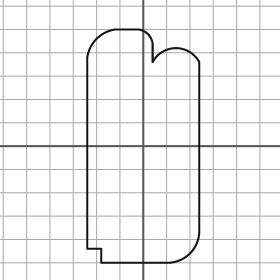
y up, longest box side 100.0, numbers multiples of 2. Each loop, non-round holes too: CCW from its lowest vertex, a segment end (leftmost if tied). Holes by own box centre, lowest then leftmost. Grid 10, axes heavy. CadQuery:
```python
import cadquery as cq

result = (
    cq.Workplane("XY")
    .moveTo(-18.0, -50.0)
    .lineTo(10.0, -50.0)
    .threePointArc((20.0, -46.0), (24.0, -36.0))
    .lineTo(24.0, 36.0)
    .threePointArc((14.0, 42.0), (4.0, 36.0))
    .lineTo(4.0, 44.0)
    .threePointArc((2.0, 48.0), (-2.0, 50.0))
    .lineTo(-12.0, 50.0)
    .threePointArc((-20.0, 46.0), (-24.0, 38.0))
    .lineTo(-24.0, -44.0)
    .lineTo(-18.0, -44.0)
    .close()
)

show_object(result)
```